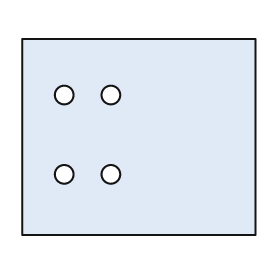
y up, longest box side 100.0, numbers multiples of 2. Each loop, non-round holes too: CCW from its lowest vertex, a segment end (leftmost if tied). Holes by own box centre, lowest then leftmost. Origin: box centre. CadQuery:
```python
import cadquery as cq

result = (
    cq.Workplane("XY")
    .moveTo(-50.0, -42.0)
    .lineTo(50.0, -42.0)
    .lineTo(50.0, 42.0)
    .lineTo(-50.0, 42.0)
    .close()
    .moveTo(-32.0, -16.0)
    .circle(4.0)
    .moveTo(-12.0, -16.0)
    .circle(4.0)
    .moveTo(-32.0, 18.0)
    .circle(4.0)
    .moveTo(-12.0, 18.0)
    .circle(4.0)
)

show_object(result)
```